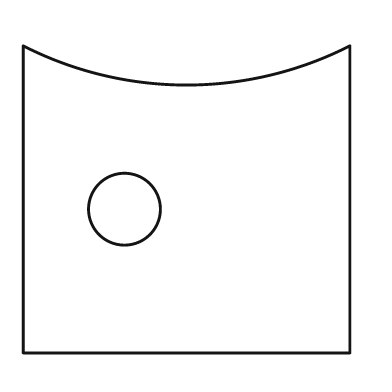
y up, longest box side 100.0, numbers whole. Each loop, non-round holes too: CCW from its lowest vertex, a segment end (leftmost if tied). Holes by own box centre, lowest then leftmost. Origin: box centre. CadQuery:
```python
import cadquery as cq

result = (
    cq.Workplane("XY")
    .moveTo(-50.0, -47.0)
    .lineTo(50.0, -47.0)
    .lineTo(50.0, 47.0)
    .threePointArc((0.0, 35.0), (-50.0, 47.0))
    .close()
    .moveTo(-19.0, -3.0)
    .circle(11.0)
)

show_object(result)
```